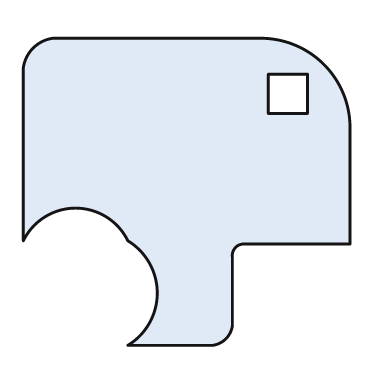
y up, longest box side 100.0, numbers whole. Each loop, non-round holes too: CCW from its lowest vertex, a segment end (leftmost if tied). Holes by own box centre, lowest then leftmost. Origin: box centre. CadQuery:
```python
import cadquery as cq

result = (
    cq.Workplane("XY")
    .moveTo(-18.0, -47.0)
    .lineTo(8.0, -47.0)
    .threePointArc((12.0, -45.0), (14.0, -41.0))
    .lineTo(14.0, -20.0)
    .threePointArc((15.0, -17.0), (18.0, -16.0))
    .lineTo(50.0, -16.0)
    .lineTo(50.0, 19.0)
    .threePointArc((42.0, 39.0), (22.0, 47.0))
    .lineTo(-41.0, 47.0)
    .threePointArc((-47.0, 44.0), (-50.0, 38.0))
    .lineTo(-50.0, -15.0)
    .threePointArc((-34.0, -5.0), (-18.0, -15.0))
    .threePointArc((-9.0, -31.0), (-18.0, -47.0))
    .close()
    .moveTo(25.0, 24.0)
    .lineTo(37.0, 24.0)
    .lineTo(37.0, 36.0)
    .lineTo(25.0, 36.0)
    .close()
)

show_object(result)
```